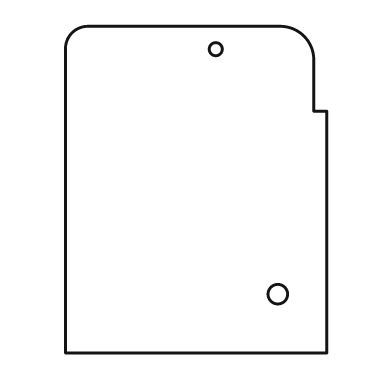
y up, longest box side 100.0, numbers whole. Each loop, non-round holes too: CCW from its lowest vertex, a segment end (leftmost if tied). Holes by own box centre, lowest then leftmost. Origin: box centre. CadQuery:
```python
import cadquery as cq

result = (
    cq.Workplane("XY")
    .moveTo(-40.0, -50.0)
    .lineTo(40.0, -50.0)
    .lineTo(40.0, 24.0)
    .lineTo(36.0, 24.0)
    .lineTo(36.0, 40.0)
    .threePointArc((33.0, 47.0), (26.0, 50.0))
    .lineTo(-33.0, 50.0)
    .threePointArc((-38.0, 48.0), (-40.0, 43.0))
    .close()
    .moveTo(25.0, -32.0)
    .circle(3.0)
    .moveTo(6.0, 43.0)
    .circle(2.0)
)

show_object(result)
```